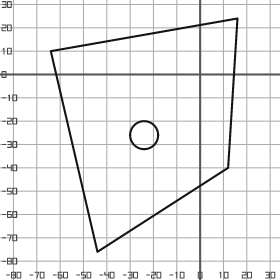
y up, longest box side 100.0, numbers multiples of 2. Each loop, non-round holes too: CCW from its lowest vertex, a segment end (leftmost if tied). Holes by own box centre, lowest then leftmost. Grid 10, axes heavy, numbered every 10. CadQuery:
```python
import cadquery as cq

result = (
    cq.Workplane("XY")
    .moveTo(-44.0, -76.0)
    .lineTo(12.0, -40.0)
    .lineTo(16.0, 24.0)
    .lineTo(-64.0, 10.0)
    .close()
    .moveTo(-24.0, -26.0)
    .circle(6.0)
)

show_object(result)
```